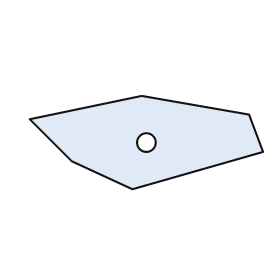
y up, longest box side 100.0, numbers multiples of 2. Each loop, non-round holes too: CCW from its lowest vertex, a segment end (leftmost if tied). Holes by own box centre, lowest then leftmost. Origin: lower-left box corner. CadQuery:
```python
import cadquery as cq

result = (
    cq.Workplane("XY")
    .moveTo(44.0, 0.0)
    .lineTo(100.0, 16.0)
    .lineTo(94.0, 32.0)
    .lineTo(48.0, 40.0)
    .lineTo(0.0, 30.0)
    .lineTo(18.0, 12.0)
    .close()
    .moveTo(50.0, 20.0)
    .circle(4.0)
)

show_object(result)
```